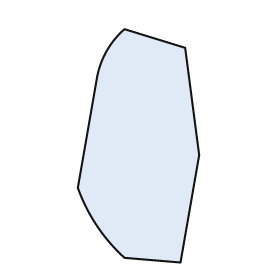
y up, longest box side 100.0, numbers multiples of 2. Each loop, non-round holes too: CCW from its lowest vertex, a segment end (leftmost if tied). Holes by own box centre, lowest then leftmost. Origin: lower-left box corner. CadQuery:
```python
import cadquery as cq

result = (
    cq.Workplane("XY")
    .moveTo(44.0, 0.0)
    .lineTo(52.0, 46.0)
    .lineTo(46.0, 92.0)
    .lineTo(20.0, 100.0)
    .threePointArc((12.0, 90.0), (8.0, 78.0))
    .lineTo(0.0, 32.0)
    .threePointArc((8.0, 16.0), (20.0, 2.0))
    .close()
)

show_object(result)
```